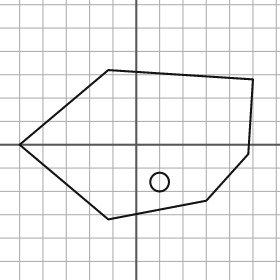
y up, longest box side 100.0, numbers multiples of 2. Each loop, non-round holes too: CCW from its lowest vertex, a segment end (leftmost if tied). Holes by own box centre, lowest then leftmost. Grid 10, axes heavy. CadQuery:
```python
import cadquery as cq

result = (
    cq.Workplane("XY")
    .moveTo(-12.0, -32.0)
    .lineTo(30.0, -24.0)
    .lineTo(48.0, -4.0)
    .lineTo(50.0, 28.0)
    .lineTo(-12.0, 32.0)
    .lineTo(-50.0, 0.0)
    .close()
    .moveTo(10.0, -16.0)
    .circle(4.0)
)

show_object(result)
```